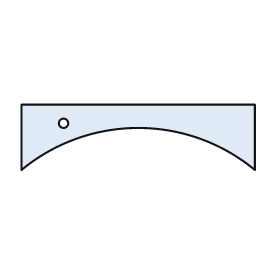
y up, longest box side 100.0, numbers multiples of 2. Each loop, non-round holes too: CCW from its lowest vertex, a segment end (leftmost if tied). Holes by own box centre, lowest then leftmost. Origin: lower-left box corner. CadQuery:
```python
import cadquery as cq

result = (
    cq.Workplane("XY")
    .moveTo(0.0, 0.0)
    .threePointArc((50.0, 18.0), (100.0, 0.0))
    .lineTo(100.0, 28.0)
    .lineTo(0.0, 28.0)
    .close()
    .moveTo(18.0, 20.0)
    .circle(2.0)
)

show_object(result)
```